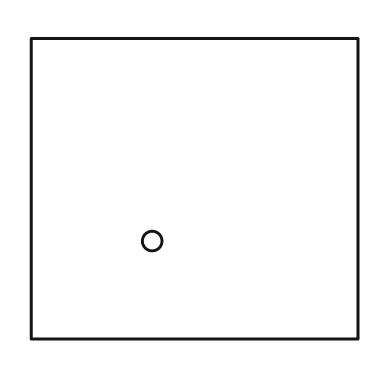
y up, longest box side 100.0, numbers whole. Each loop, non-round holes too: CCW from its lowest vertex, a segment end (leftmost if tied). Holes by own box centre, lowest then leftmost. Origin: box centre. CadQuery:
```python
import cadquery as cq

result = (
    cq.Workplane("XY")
    .moveTo(-50.0, -46.0)
    .lineTo(50.0, -46.0)
    .lineTo(50.0, 46.0)
    .lineTo(-50.0, 46.0)
    .close()
    .moveTo(-13.0, -16.0)
    .circle(3.0)
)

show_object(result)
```